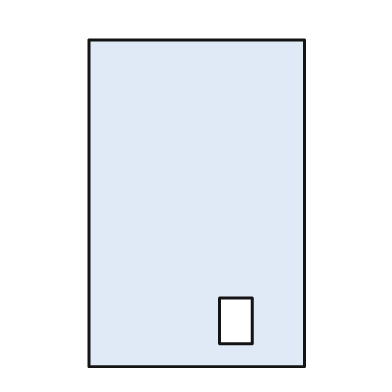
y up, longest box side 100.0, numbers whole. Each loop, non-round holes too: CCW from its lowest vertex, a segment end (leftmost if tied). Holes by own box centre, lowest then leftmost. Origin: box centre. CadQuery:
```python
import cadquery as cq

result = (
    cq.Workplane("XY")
    .moveTo(-33.0, -50.0)
    .lineTo(33.0, -50.0)
    .lineTo(33.0, 50.0)
    .lineTo(-33.0, 50.0)
    .close()
    .moveTo(7.0, -43.0)
    .lineTo(17.0, -43.0)
    .lineTo(17.0, -29.0)
    .lineTo(7.0, -29.0)
    .close()
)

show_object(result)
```